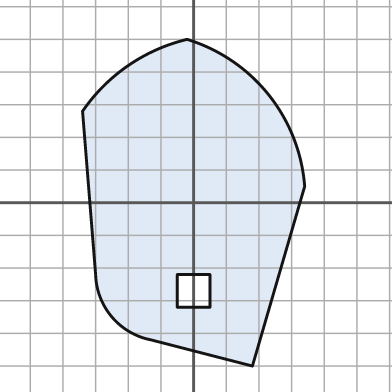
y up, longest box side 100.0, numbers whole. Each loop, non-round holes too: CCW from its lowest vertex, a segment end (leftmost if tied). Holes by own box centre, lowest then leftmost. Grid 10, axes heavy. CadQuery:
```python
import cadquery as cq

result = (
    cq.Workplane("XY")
    .moveTo(18.0, -50.0)
    .lineTo(34.0, 5.0)
    .threePointArc((23.0, 33.0), (-2.0, 50.0))
    .threePointArc((-20.0, 42.0), (-34.0, 28.0))
    .lineTo(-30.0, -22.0)
    .threePointArc((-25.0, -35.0), (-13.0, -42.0))
    .close()
    .moveTo(-5.0, -32.0)
    .lineTo(5.0, -32.0)
    .lineTo(5.0, -22.0)
    .lineTo(-5.0, -22.0)
    .close()
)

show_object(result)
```